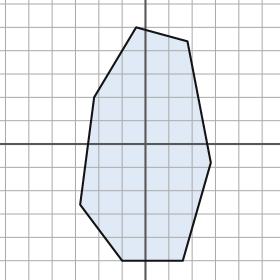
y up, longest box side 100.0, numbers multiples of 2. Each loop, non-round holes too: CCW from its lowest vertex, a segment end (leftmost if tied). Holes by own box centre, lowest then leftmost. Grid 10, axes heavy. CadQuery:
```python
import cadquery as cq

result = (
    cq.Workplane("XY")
    .moveTo(-10.0, -50.0)
    .lineTo(16.0, -50.0)
    .lineTo(28.0, -8.0)
    .lineTo(18.0, 44.0)
    .lineTo(-4.0, 50.0)
    .lineTo(-22.0, 20.0)
    .lineTo(-28.0, -26.0)
    .close()
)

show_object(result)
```